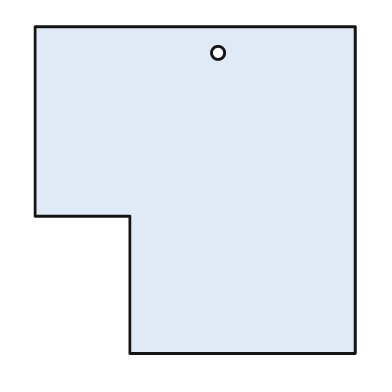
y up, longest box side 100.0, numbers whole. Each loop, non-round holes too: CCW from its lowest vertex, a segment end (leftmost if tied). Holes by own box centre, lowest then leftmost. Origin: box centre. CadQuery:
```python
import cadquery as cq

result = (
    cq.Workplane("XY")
    .moveTo(-20.0, -50.0)
    .lineTo(49.0, -50.0)
    .lineTo(49.0, 50.0)
    .lineTo(-49.0, 50.0)
    .lineTo(-49.0, -8.0)
    .lineTo(-20.0, -8.0)
    .close()
    .moveTo(7.0, 42.0)
    .circle(2.0)
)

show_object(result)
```